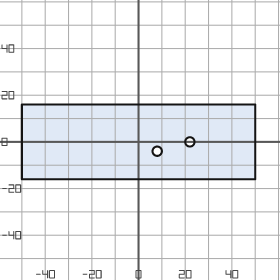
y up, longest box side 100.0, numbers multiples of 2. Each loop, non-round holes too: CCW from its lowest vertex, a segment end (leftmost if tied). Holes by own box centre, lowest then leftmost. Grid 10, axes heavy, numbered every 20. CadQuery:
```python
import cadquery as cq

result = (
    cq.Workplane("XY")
    .moveTo(-50.0, -16.0)
    .lineTo(50.0, -16.0)
    .lineTo(50.0, 16.0)
    .lineTo(-50.0, 16.0)
    .close()
    .moveTo(8.0, -4.0)
    .circle(2.0)
    .moveTo(22.0, 0.0)
    .circle(2.0)
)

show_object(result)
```